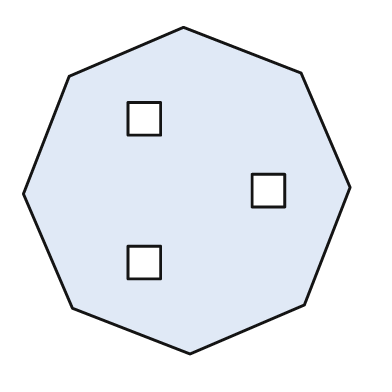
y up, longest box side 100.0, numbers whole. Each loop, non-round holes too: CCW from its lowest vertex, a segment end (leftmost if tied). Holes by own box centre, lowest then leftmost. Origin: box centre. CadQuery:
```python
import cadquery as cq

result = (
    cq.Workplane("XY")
    .moveTo(1.0, -50.0)
    .lineTo(36.0, -35.0)
    .lineTo(50.0, 1.0)
    .lineTo(35.0, 36.0)
    .lineTo(-1.0, 50.0)
    .lineTo(-36.0, 35.0)
    .lineTo(-50.0, -1.0)
    .lineTo(-35.0, -36.0)
    .close()
    .moveTo(-18.0, -27.0)
    .lineTo(-8.0, -27.0)
    .lineTo(-8.0, -17.0)
    .lineTo(-18.0, -17.0)
    .close()
    .moveTo(20.0, -5.0)
    .lineTo(30.0, -5.0)
    .lineTo(30.0, 5.0)
    .lineTo(20.0, 5.0)
    .close()
    .moveTo(-18.0, 17.0)
    .lineTo(-8.0, 17.0)
    .lineTo(-8.0, 27.0)
    .lineTo(-18.0, 27.0)
    .close()
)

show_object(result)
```